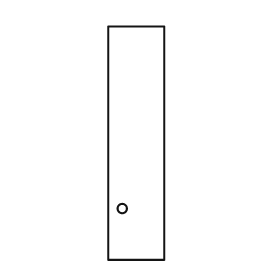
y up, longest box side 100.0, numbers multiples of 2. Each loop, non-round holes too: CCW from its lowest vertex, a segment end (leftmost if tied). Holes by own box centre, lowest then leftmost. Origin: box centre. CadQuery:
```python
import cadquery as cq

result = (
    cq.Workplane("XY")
    .moveTo(-12.0, -50.0)
    .lineTo(12.0, -50.0)
    .lineTo(12.0, 50.0)
    .lineTo(-12.0, 50.0)
    .close()
    .moveTo(-6.0, -28.0)
    .circle(2.0)
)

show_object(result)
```